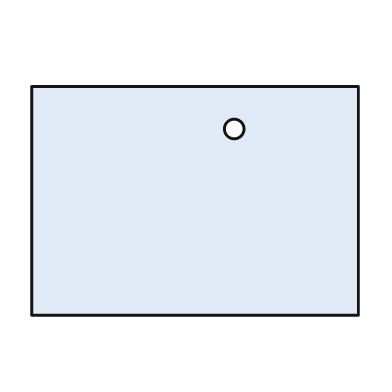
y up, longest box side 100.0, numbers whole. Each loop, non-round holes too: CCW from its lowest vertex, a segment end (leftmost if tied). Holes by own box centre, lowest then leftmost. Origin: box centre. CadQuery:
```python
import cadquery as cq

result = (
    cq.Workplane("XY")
    .moveTo(-50.0, -35.0)
    .lineTo(50.0, -35.0)
    .lineTo(50.0, 35.0)
    .lineTo(-50.0, 35.0)
    .close()
    .moveTo(12.0, 22.0)
    .circle(3.0)
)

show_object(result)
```